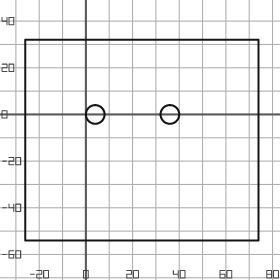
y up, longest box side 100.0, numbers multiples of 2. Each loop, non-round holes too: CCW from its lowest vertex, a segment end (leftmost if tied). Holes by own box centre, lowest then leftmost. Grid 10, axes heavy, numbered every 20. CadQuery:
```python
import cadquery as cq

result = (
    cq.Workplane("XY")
    .moveTo(-26.0, -54.0)
    .lineTo(74.0, -54.0)
    .lineTo(74.0, 32.0)
    .lineTo(-26.0, 32.0)
    .close()
    .moveTo(4.0, 0.0)
    .circle(4.0)
    .moveTo(36.0, 0.0)
    .circle(4.0)
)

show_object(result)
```